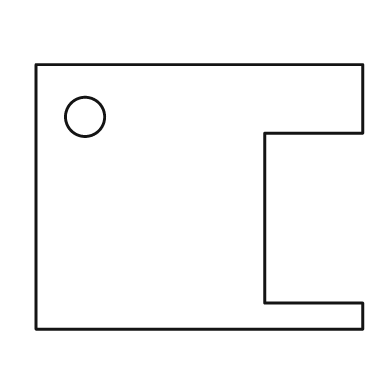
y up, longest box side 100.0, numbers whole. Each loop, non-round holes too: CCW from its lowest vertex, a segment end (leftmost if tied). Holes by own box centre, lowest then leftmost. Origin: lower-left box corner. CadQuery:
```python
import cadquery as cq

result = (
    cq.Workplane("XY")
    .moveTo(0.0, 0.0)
    .lineTo(100.0, 0.0)
    .lineTo(100.0, 8.0)
    .lineTo(70.0, 8.0)
    .lineTo(70.0, 60.0)
    .lineTo(100.0, 60.0)
    .lineTo(100.0, 81.0)
    .lineTo(0.0, 81.0)
    .close()
    .moveTo(15.0, 65.0)
    .circle(6.0)
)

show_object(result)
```